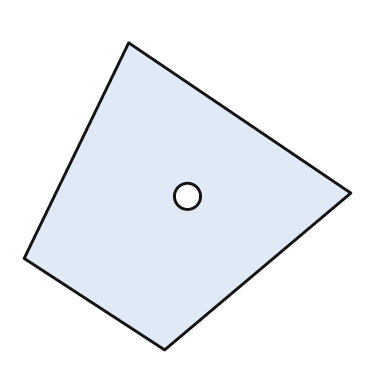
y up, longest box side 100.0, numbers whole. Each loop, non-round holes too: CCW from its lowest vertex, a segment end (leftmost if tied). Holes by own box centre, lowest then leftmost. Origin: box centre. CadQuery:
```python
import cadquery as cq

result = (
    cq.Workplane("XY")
    .moveTo(-7.0, -47.0)
    .lineTo(50.0, 1.0)
    .lineTo(-18.0, 47.0)
    .lineTo(-50.0, -19.0)
    .close()
    .moveTo(0.0, 0.0)
    .circle(4.0)
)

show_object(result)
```